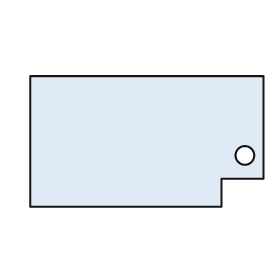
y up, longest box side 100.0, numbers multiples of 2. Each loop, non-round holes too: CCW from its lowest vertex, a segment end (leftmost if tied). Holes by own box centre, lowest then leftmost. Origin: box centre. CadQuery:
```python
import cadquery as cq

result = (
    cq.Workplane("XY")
    .moveTo(-50.0, -28.0)
    .lineTo(32.0, -28.0)
    .lineTo(32.0, -16.0)
    .lineTo(50.0, -16.0)
    .lineTo(50.0, 28.0)
    .lineTo(-50.0, 28.0)
    .close()
    .moveTo(42.0, -6.0)
    .circle(4.0)
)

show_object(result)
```